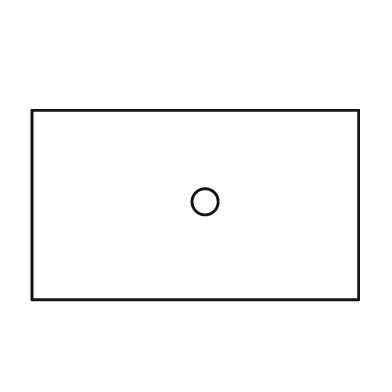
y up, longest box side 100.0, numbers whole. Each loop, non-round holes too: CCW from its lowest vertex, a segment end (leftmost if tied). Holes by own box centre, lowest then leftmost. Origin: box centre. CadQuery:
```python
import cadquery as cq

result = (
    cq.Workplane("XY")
    .moveTo(-50.0, -29.0)
    .lineTo(50.0, -29.0)
    .lineTo(50.0, 29.0)
    .lineTo(-50.0, 29.0)
    .close()
    .moveTo(3.0, 1.0)
    .circle(4.0)
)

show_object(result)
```